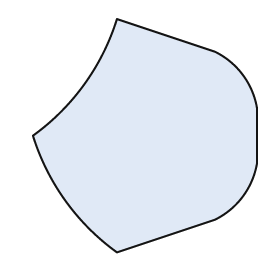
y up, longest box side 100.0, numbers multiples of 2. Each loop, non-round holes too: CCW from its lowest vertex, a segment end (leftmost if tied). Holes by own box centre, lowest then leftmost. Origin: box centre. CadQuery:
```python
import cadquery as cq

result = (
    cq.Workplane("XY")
    .moveTo(-12.0, -50.0)
    .lineTo(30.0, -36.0)
    .threePointArc((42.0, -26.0), (48.0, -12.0))
    .lineTo(48.0, 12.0)
    .threePointArc((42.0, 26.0), (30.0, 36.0))
    .lineTo(-12.0, 50.0)
    .threePointArc((-26.0, 22.0), (-48.0, 0.0))
    .threePointArc((-34.0, -28.0), (-12.0, -50.0))
    .close()
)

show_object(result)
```